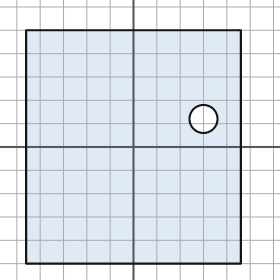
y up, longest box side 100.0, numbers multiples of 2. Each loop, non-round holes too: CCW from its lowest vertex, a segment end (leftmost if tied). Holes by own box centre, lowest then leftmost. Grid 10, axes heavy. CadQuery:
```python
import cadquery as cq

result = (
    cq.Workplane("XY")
    .moveTo(-46.0, -50.0)
    .lineTo(46.0, -50.0)
    .lineTo(46.0, 50.0)
    .lineTo(-46.0, 50.0)
    .close()
    .moveTo(30.0, 12.0)
    .circle(6.0)
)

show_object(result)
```